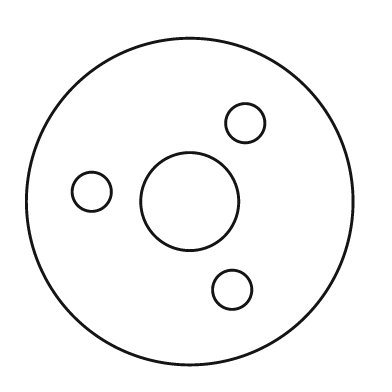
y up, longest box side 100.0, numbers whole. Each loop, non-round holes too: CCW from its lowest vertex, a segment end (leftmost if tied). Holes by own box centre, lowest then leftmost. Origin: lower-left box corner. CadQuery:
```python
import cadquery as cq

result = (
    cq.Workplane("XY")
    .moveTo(50.0, 50.0)
    .circle(50.0)
    .moveTo(63.0, 23.0)
    .circle(6.0)
    .moveTo(50.0, 50.0)
    .circle(15.0)
    .moveTo(20.0, 53.0)
    .circle(6.0)
    .moveTo(67.0, 74.0)
    .circle(6.0)
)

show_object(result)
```